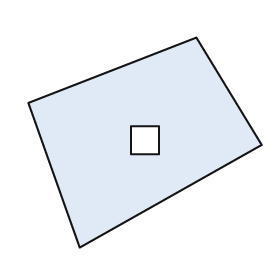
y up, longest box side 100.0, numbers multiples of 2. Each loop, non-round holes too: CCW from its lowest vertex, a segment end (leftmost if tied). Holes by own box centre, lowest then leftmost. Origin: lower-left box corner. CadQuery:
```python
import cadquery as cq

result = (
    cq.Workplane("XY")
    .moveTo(22.0, 0.0)
    .lineTo(100.0, 44.0)
    .lineTo(72.0, 90.0)
    .lineTo(0.0, 62.0)
    .close()
    .moveTo(44.0, 40.0)
    .lineTo(56.0, 40.0)
    .lineTo(56.0, 52.0)
    .lineTo(44.0, 52.0)
    .close()
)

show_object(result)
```